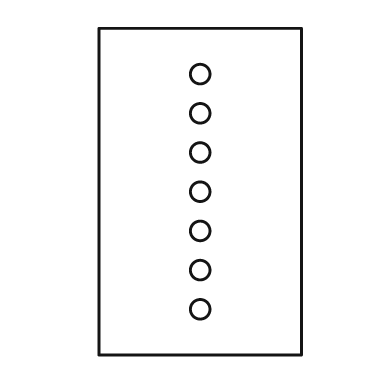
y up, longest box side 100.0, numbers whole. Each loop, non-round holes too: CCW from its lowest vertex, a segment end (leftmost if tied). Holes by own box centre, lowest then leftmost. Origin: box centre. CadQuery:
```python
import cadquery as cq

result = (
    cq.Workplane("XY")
    .moveTo(-31.0, -50.0)
    .lineTo(31.0, -50.0)
    .lineTo(31.0, 50.0)
    .lineTo(-31.0, 50.0)
    .close()
    .moveTo(0.0, -36.0)
    .circle(3.0)
    .moveTo(0.0, -24.0)
    .circle(3.0)
    .moveTo(0.0, -12.0)
    .circle(3.0)
    .moveTo(0.0, 0.0)
    .circle(3.0)
    .moveTo(0.0, 12.0)
    .circle(3.0)
    .moveTo(0.0, 24.0)
    .circle(3.0)
    .moveTo(0.0, 36.0)
    .circle(3.0)
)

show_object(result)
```